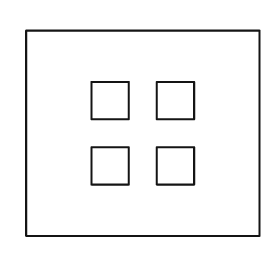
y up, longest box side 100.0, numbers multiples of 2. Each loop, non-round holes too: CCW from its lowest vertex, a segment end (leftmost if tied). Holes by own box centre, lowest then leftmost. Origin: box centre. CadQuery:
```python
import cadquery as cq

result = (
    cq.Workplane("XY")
    .moveTo(-50.0, -44.0)
    .lineTo(50.0, -44.0)
    .lineTo(50.0, 44.0)
    .lineTo(-50.0, 44.0)
    .close()
    .moveTo(-22.0, -22.0)
    .lineTo(-6.0, -22.0)
    .lineTo(-6.0, -6.0)
    .lineTo(-22.0, -6.0)
    .close()
    .moveTo(6.0, -22.0)
    .lineTo(22.0, -22.0)
    .lineTo(22.0, -6.0)
    .lineTo(6.0, -6.0)
    .close()
    .moveTo(-22.0, 6.0)
    .lineTo(-6.0, 6.0)
    .lineTo(-6.0, 22.0)
    .lineTo(-22.0, 22.0)
    .close()
    .moveTo(6.0, 6.0)
    .lineTo(22.0, 6.0)
    .lineTo(22.0, 22.0)
    .lineTo(6.0, 22.0)
    .close()
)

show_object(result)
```